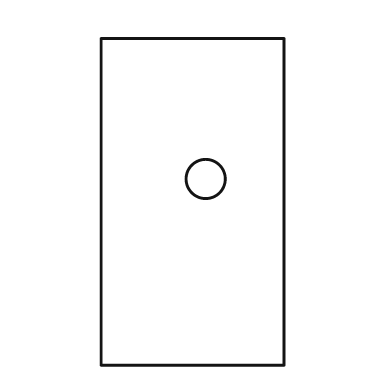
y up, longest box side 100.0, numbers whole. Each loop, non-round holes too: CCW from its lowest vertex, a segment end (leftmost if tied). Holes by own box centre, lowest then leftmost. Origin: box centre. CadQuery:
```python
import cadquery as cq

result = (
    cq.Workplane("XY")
    .moveTo(-28.0, -50.0)
    .lineTo(28.0, -50.0)
    .lineTo(28.0, 50.0)
    .lineTo(-28.0, 50.0)
    .close()
    .moveTo(4.0, 7.0)
    .circle(6.0)
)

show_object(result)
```